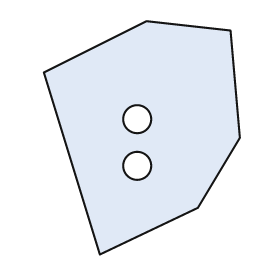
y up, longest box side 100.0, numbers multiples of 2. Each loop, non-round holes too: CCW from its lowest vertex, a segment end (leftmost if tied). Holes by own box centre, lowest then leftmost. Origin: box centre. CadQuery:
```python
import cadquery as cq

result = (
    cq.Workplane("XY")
    .moveTo(-18.0, -50.0)
    .lineTo(24.0, -30.0)
    .lineTo(42.0, 0.0)
    .lineTo(38.0, 46.0)
    .lineTo(2.0, 50.0)
    .lineTo(-42.0, 28.0)
    .close()
    .moveTo(-2.0, -12.0)
    .circle(6.0)
    .moveTo(-2.0, 8.0)
    .circle(6.0)
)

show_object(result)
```